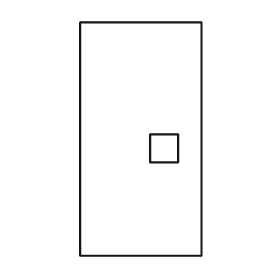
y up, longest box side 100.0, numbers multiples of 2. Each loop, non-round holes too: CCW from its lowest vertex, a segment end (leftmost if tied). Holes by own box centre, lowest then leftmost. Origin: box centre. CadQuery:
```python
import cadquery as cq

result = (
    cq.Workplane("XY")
    .moveTo(-26.0, -50.0)
    .lineTo(26.0, -50.0)
    .lineTo(26.0, 50.0)
    .lineTo(-26.0, 50.0)
    .close()
    .moveTo(4.0, -10.0)
    .lineTo(16.0, -10.0)
    .lineTo(16.0, 2.0)
    .lineTo(4.0, 2.0)
    .close()
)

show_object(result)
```